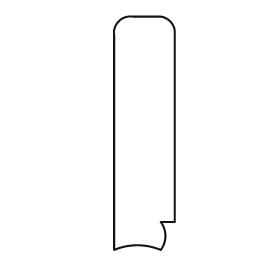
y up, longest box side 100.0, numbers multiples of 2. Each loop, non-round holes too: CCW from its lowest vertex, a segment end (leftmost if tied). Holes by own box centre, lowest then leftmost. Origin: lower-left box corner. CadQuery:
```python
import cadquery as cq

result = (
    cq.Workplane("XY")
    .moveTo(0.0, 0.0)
    .threePointArc((10.0, 2.0), (20.0, 0.0))
    .threePointArc((22.0, 6.0), (20.0, 12.0))
    .lineTo(26.0, 12.0)
    .lineTo(26.0, 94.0)
    .threePointArc((24.0, 98.0), (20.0, 100.0))
    .lineTo(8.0, 100.0)
    .threePointArc((2.0, 98.0), (0.0, 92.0))
    .close()
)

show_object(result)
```